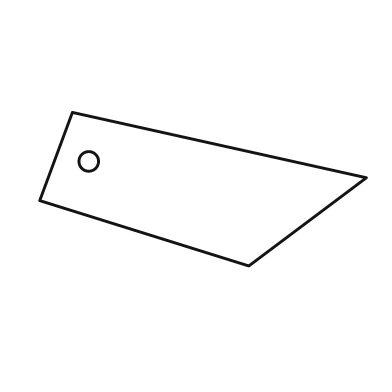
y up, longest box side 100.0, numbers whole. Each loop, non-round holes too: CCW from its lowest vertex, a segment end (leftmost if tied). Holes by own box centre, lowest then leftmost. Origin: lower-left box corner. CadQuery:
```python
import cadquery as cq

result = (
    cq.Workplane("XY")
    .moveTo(64.0, 0.0)
    .lineTo(100.0, 27.0)
    .lineTo(10.0, 47.0)
    .lineTo(0.0, 20.0)
    .close()
    .moveTo(15.0, 32.0)
    .circle(3.0)
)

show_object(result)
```